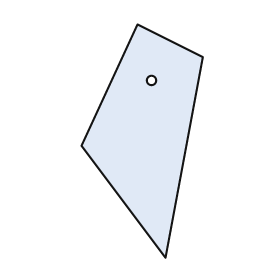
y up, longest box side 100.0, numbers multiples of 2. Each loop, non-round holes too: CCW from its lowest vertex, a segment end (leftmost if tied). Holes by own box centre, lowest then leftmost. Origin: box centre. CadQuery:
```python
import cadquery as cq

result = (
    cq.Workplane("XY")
    .moveTo(10.0, -50.0)
    .lineTo(26.0, 36.0)
    .lineTo(-2.0, 50.0)
    .lineTo(-26.0, -2.0)
    .close()
    .moveTo(4.0, 26.0)
    .circle(2.0)
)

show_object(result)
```